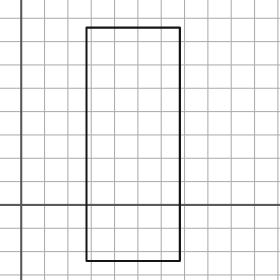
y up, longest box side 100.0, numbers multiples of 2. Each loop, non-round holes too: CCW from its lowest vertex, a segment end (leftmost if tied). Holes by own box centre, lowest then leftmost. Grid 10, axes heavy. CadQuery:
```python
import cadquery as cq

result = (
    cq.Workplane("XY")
    .moveTo(28.0, -24.0)
    .lineTo(68.0, -24.0)
    .lineTo(68.0, 76.0)
    .lineTo(28.0, 76.0)
    .close()
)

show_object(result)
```